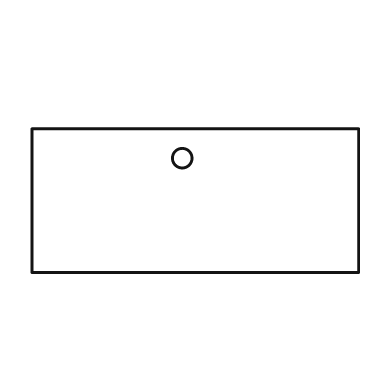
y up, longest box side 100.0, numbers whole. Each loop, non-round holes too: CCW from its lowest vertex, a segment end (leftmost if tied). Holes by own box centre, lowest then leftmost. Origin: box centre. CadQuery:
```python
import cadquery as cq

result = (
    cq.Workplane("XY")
    .moveTo(-50.0, -22.0)
    .lineTo(50.0, -22.0)
    .lineTo(50.0, 22.0)
    .lineTo(-50.0, 22.0)
    .close()
    .moveTo(-4.0, 13.0)
    .circle(3.0)
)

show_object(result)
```